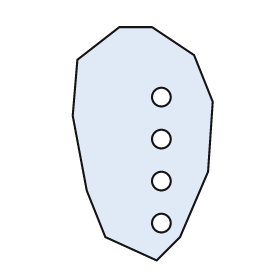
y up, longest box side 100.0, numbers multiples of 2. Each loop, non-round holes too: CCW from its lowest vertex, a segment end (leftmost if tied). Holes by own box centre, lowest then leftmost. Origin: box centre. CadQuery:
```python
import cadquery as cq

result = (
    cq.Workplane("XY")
    .moveTo(6.0, -50.0)
    .lineTo(16.0, -40.0)
    .lineTo(28.0, -12.0)
    .lineTo(30.0, 18.0)
    .lineTo(22.0, 38.0)
    .lineTo(4.0, 50.0)
    .lineTo(-10.0, 50.0)
    .lineTo(-28.0, 36.0)
    .lineTo(-30.0, 12.0)
    .lineTo(-24.0, -20.0)
    .lineTo(-16.0, -40.0)
    .close()
    .moveTo(8.0, -34.0)
    .circle(4.0)
    .moveTo(8.0, -16.0)
    .circle(4.0)
    .moveTo(8.0, 2.0)
    .circle(4.0)
    .moveTo(8.0, 20.0)
    .circle(4.0)
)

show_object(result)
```